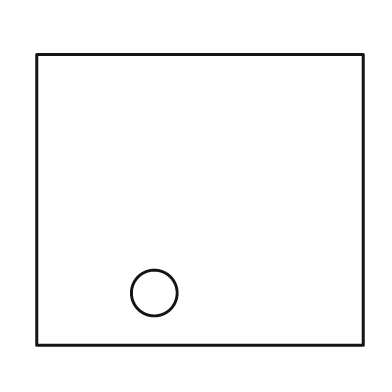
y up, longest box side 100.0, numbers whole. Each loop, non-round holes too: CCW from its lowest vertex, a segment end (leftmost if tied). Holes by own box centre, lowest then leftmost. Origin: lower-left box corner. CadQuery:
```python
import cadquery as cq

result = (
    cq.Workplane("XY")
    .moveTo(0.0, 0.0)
    .lineTo(100.0, 0.0)
    .lineTo(100.0, 89.0)
    .lineTo(0.0, 89.0)
    .close()
    .moveTo(36.0, 16.0)
    .circle(7.0)
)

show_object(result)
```